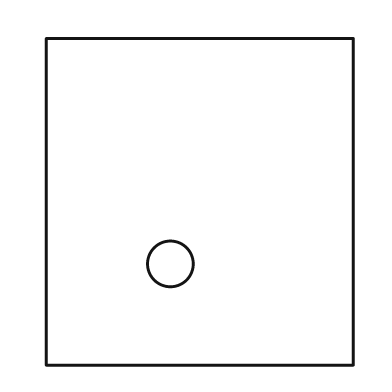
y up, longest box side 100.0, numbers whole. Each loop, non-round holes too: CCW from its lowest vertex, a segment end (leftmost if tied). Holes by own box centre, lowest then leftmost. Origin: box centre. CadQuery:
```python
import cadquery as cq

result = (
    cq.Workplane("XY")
    .moveTo(-47.0, -50.0)
    .lineTo(47.0, -50.0)
    .lineTo(47.0, 50.0)
    .lineTo(-47.0, 50.0)
    .close()
    .moveTo(-9.0, -19.0)
    .circle(7.0)
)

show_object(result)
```